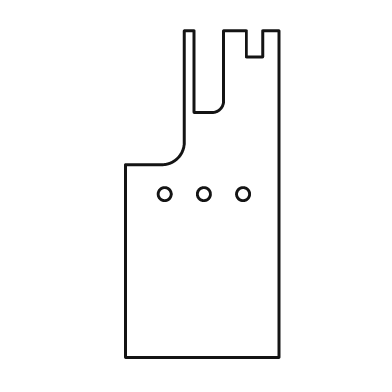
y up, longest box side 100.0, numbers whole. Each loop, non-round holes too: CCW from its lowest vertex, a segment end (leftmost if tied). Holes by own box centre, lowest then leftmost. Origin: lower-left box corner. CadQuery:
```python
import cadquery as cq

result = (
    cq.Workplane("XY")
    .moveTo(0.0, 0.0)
    .lineTo(47.0, 0.0)
    .lineTo(47.0, 100.0)
    .lineTo(42.0, 100.0)
    .lineTo(42.0, 92.0)
    .lineTo(37.0, 92.0)
    .lineTo(37.0, 100.0)
    .lineTo(30.0, 100.0)
    .lineTo(30.0, 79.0)
    .threePointArc((29.0, 76.0), (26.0, 75.0))
    .lineTo(21.0, 75.0)
    .lineTo(21.0, 100.0)
    .lineTo(18.0, 100.0)
    .lineTo(18.0, 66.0)
    .threePointArc((16.0, 61.0), (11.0, 59.0))
    .lineTo(0.0, 59.0)
    .close()
    .moveTo(12.0, 50.0)
    .circle(2.0)
    .moveTo(24.0, 50.0)
    .circle(2.0)
    .moveTo(36.0, 50.0)
    .circle(2.0)
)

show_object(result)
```